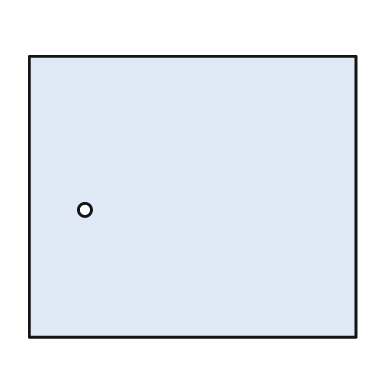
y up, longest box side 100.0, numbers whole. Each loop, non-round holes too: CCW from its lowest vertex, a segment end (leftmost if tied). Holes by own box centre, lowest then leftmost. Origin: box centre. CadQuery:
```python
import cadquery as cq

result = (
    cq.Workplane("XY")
    .moveTo(-50.0, -43.0)
    .lineTo(50.0, -43.0)
    .lineTo(50.0, 43.0)
    .lineTo(-50.0, 43.0)
    .close()
    .moveTo(-33.0, -4.0)
    .circle(2.0)
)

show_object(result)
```